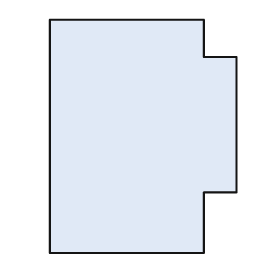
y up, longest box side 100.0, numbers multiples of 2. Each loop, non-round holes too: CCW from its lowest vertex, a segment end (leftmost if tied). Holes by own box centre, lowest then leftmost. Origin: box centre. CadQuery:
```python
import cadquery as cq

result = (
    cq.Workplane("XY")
    .moveTo(-40.0, -50.0)
    .lineTo(26.0, -50.0)
    .lineTo(26.0, -24.0)
    .lineTo(40.0, -24.0)
    .lineTo(40.0, 34.0)
    .lineTo(26.0, 34.0)
    .lineTo(26.0, 50.0)
    .lineTo(-40.0, 50.0)
    .close()
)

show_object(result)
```